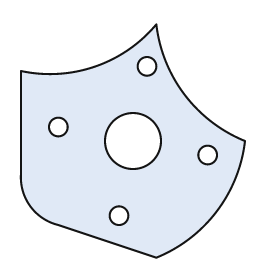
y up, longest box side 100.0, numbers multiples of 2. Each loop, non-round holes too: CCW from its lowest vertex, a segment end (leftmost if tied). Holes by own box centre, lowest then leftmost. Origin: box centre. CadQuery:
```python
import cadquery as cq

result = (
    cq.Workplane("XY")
    .moveTo(10.0, -50.0)
    .threePointArc((36.0, -30.0), (48.0, 0.0))
    .threePointArc((22.0, 20.0), (10.0, 50.0))
    .threePointArc((-16.0, 32.0), (-48.0, 30.0))
    .lineTo(-48.0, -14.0)
    .threePointArc((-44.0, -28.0), (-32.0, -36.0))
    .close()
    .moveTo(-6.0, -32.0)
    .circle(4.0)
    .moveTo(32.0, -6.0)
    .circle(4.0)
    .moveTo(0.0, 0.0)
    .circle(12.0)
    .moveTo(-32.0, 6.0)
    .circle(4.0)
    .moveTo(6.0, 32.0)
    .circle(4.0)
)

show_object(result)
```